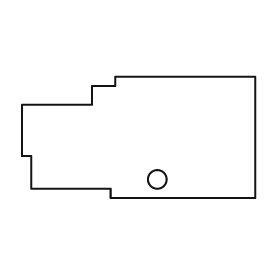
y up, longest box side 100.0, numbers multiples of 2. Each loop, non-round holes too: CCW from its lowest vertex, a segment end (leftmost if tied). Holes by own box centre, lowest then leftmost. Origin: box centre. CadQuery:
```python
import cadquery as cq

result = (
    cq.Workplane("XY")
    .moveTo(-12.0, -26.0)
    .lineTo(50.0, -26.0)
    .lineTo(50.0, 26.0)
    .lineTo(-10.0, 26.0)
    .lineTo(-10.0, 22.0)
    .lineTo(-20.0, 22.0)
    .lineTo(-20.0, 14.0)
    .lineTo(-50.0, 14.0)
    .lineTo(-50.0, -8.0)
    .lineTo(-46.0, -8.0)
    .lineTo(-46.0, -22.0)
    .lineTo(-12.0, -22.0)
    .close()
    .moveTo(8.0, -18.0)
    .circle(4.0)
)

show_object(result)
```